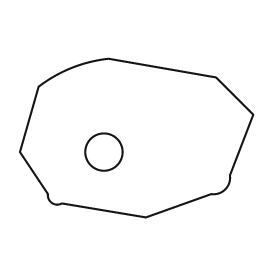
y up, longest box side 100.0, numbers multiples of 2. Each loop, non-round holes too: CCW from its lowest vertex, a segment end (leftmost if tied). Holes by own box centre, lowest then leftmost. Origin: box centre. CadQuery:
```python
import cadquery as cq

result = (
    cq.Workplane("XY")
    .moveTo(4.0, -34.0)
    .lineTo(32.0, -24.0)
    .threePointArc((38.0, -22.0), (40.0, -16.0))
    .lineTo(50.0, 10.0)
    .lineTo(34.0, 26.0)
    .lineTo(-12.0, 34.0)
    .threePointArc((-28.0, 30.0), (-42.0, 22.0))
    .lineTo(-50.0, -6.0)
    .lineTo(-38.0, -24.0)
    .threePointArc((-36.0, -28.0), (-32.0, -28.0))
    .close()
    .moveTo(-14.0, -6.0)
    .circle(8.0)
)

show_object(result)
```